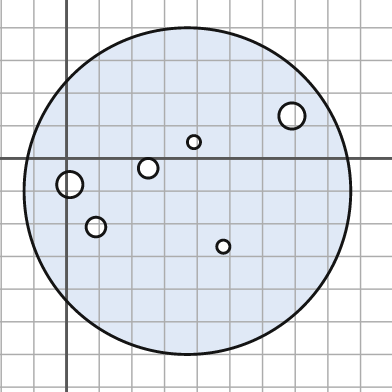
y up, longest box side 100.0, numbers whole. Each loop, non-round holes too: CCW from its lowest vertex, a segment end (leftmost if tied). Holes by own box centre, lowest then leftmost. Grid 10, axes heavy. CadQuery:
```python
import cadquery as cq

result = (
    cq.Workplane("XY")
    .moveTo(37.0, -10.0)
    .circle(50.0)
    .moveTo(48.0, -27.0)
    .circle(2.0)
    .moveTo(9.0, -21.0)
    .circle(3.0)
    .moveTo(1.0, -8.0)
    .circle(4.0)
    .moveTo(25.0, -3.0)
    .circle(3.0)
    .moveTo(39.0, 5.0)
    .circle(2.0)
    .moveTo(69.0, 13.0)
    .circle(4.0)
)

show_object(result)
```